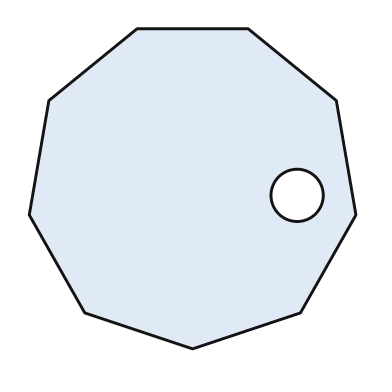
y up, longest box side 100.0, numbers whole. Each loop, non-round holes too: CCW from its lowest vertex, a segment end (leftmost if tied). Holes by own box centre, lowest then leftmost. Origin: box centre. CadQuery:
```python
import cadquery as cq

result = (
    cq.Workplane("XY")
    .moveTo(0.0, -49.0)
    .lineTo(33.0, -38.0)
    .lineTo(50.0, -8.0)
    .lineTo(44.0, 27.0)
    .lineTo(17.0, 49.0)
    .lineTo(-17.0, 49.0)
    .lineTo(-44.0, 27.0)
    .lineTo(-50.0, -8.0)
    .lineTo(-33.0, -38.0)
    .close()
    .moveTo(32.0, -2.0)
    .circle(8.0)
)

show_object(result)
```